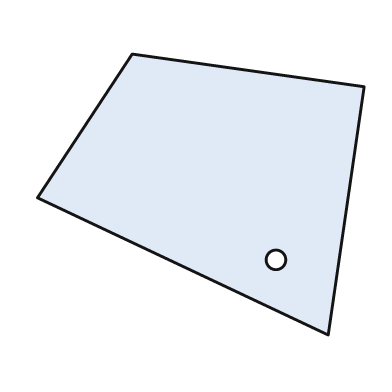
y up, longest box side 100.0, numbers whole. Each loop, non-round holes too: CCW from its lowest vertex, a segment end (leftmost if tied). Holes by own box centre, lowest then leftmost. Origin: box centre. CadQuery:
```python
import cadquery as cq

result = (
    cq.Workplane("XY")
    .moveTo(39.0, -43.0)
    .lineTo(50.0, 33.0)
    .lineTo(-21.0, 43.0)
    .lineTo(-50.0, -1.0)
    .close()
    .moveTo(23.0, -20.0)
    .circle(3.0)
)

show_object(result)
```